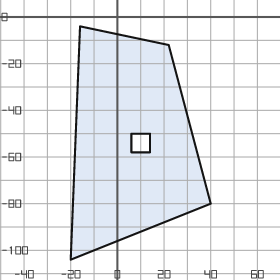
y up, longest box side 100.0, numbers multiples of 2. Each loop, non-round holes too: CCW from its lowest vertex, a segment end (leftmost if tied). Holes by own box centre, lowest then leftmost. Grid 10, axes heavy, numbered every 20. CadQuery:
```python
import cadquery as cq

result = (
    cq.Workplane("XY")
    .moveTo(-20.0, -104.0)
    .lineTo(40.0, -80.0)
    .lineTo(22.0, -12.0)
    .lineTo(-16.0, -4.0)
    .close()
    .moveTo(6.0, -58.0)
    .lineTo(14.0, -58.0)
    .lineTo(14.0, -50.0)
    .lineTo(6.0, -50.0)
    .close()
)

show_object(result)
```